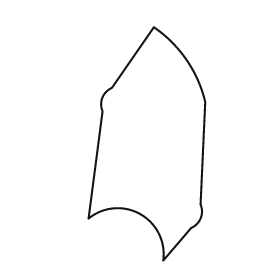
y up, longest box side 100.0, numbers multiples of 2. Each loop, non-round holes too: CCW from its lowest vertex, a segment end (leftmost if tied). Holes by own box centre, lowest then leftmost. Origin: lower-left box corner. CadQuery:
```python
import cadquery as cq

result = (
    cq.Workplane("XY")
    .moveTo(32.0, 0.0)
    .lineTo(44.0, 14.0)
    .threePointArc((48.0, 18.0), (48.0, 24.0))
    .lineTo(50.0, 68.0)
    .threePointArc((42.0, 86.0), (28.0, 100.0))
    .lineTo(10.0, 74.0)
    .threePointArc((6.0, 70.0), (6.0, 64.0))
    .lineTo(0.0, 18.0)
    .threePointArc((22.0, 20.0), (32.0, 0.0))
    .close()
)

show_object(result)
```